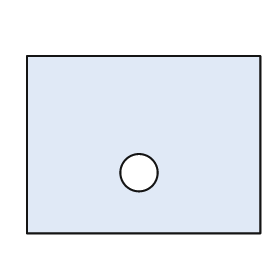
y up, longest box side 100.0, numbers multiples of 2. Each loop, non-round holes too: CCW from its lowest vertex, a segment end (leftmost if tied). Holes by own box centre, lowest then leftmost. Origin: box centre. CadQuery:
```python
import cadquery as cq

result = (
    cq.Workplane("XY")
    .moveTo(-50.0, -38.0)
    .lineTo(50.0, -38.0)
    .lineTo(50.0, 38.0)
    .lineTo(-50.0, 38.0)
    .close()
    .moveTo(-2.0, -12.0)
    .circle(8.0)
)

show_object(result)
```